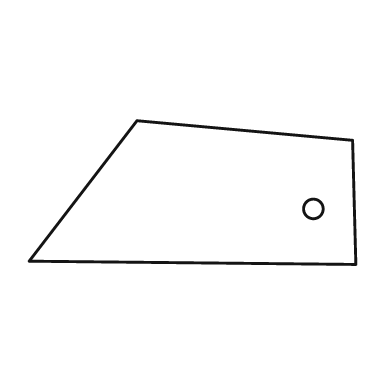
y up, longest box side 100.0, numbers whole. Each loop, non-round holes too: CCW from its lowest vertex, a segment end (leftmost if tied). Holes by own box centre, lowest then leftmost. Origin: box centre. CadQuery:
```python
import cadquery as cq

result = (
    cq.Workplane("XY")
    .moveTo(50.0, -22.0)
    .lineTo(49.0, 16.0)
    .lineTo(-17.0, 22.0)
    .lineTo(-50.0, -21.0)
    .close()
    .moveTo(37.0, -5.0)
    .circle(3.0)
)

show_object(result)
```